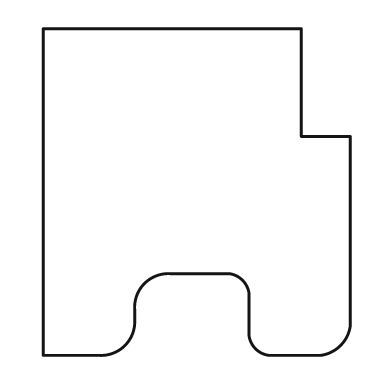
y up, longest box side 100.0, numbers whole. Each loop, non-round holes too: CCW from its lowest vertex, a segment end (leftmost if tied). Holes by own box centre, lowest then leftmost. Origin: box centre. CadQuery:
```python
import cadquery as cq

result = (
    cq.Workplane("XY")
    .moveTo(-47.0, -50.0)
    .lineTo(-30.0, -50.0)
    .threePointArc((-22.0, -47.0), (-19.0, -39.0))
    .lineTo(-19.0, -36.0)
    .threePointArc((-16.0, -28.0), (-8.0, -25.0))
    .lineTo(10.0, -25.0)
    .threePointArc((14.0, -27.0), (16.0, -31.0))
    .lineTo(16.0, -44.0)
    .threePointArc((18.0, -48.0), (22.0, -50.0))
    .lineTo(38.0, -50.0)
    .threePointArc((44.0, -47.0), (47.0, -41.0))
    .lineTo(47.0, 17.0)
    .lineTo(32.0, 17.0)
    .lineTo(32.0, 50.0)
    .lineTo(-47.0, 50.0)
    .close()
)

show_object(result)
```